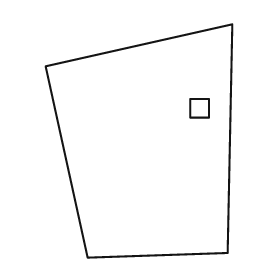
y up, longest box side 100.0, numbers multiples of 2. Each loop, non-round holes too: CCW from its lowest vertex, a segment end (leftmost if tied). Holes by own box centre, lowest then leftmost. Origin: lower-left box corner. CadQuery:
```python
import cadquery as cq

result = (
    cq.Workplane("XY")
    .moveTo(18.0, 0.0)
    .lineTo(78.0, 2.0)
    .lineTo(80.0, 100.0)
    .lineTo(0.0, 82.0)
    .close()
    .moveTo(62.0, 60.0)
    .lineTo(70.0, 60.0)
    .lineTo(70.0, 68.0)
    .lineTo(62.0, 68.0)
    .close()
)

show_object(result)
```